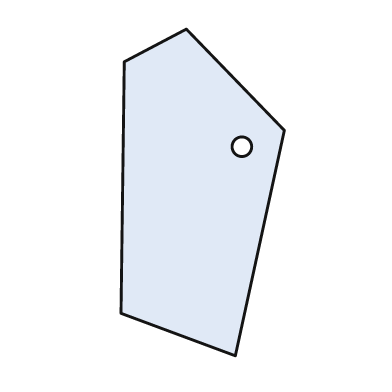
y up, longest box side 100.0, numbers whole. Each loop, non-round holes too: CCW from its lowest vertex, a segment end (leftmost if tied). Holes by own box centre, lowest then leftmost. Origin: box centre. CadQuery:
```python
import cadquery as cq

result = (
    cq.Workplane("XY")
    .moveTo(10.0, -50.0)
    .lineTo(25.0, 19.0)
    .lineTo(-5.0, 50.0)
    .lineTo(-24.0, 40.0)
    .lineTo(-25.0, -37.0)
    .close()
    .moveTo(12.0, 14.0)
    .circle(3.0)
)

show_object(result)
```